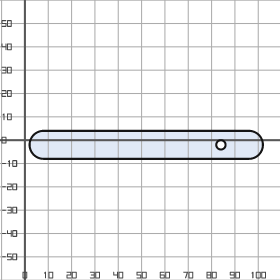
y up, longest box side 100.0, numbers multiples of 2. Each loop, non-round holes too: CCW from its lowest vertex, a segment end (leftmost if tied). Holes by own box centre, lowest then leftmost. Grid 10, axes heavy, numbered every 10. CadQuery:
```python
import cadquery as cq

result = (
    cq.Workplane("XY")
    .moveTo(8.0, -8.0)
    .lineTo(96.0, -8.0)
    .threePointArc((102.0, -2.0), (96.0, 4.0))
    .lineTo(8.0, 4.0)
    .threePointArc((2.0, -2.0), (8.0, -8.0))
    .close()
    .moveTo(84.0, -2.0)
    .circle(2.0)
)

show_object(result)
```